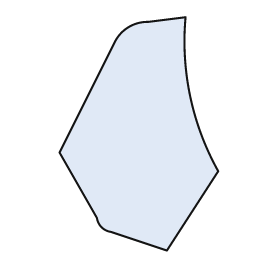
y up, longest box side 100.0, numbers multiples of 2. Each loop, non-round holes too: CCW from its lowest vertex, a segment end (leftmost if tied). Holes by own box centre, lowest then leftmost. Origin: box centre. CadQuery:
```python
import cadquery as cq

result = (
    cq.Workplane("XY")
    .moveTo(12.0, -50.0)
    .lineTo(34.0, -16.0)
    .threePointArc((22.0, 16.0), (20.0, 50.0))
    .lineTo(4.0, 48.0)
    .threePointArc((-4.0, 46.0), (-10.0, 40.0))
    .lineTo(-34.0, -8.0)
    .lineTo(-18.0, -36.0)
    .threePointArc((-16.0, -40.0), (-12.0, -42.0))
    .close()
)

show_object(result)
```